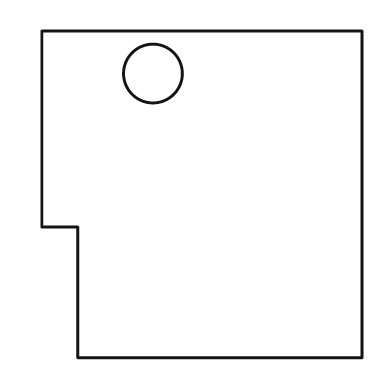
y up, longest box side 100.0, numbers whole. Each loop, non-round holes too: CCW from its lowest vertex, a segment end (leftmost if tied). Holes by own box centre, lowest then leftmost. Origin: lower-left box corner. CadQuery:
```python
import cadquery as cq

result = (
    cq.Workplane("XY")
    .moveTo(11.0, 0.0)
    .lineTo(98.0, 0.0)
    .lineTo(98.0, 100.0)
    .lineTo(0.0, 100.0)
    .lineTo(0.0, 40.0)
    .lineTo(11.0, 40.0)
    .close()
    .moveTo(34.0, 87.0)
    .circle(9.0)
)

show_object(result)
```